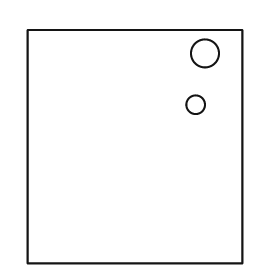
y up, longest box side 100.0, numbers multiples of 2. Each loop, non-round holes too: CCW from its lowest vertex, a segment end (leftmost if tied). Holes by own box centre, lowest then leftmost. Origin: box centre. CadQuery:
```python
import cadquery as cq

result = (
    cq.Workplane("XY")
    .moveTo(-46.0, -50.0)
    .lineTo(46.0, -50.0)
    .lineTo(46.0, 50.0)
    .lineTo(-46.0, 50.0)
    .close()
    .moveTo(26.0, 18.0)
    .circle(4.0)
    .moveTo(30.0, 40.0)
    .circle(6.0)
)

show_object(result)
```